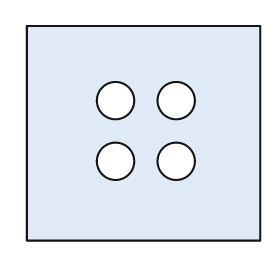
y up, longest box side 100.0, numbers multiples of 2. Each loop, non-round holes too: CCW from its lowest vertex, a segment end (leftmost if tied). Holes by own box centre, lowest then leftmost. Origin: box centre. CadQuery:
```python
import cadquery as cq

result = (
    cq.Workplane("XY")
    .moveTo(-50.0, -46.0)
    .lineTo(50.0, -46.0)
    .lineTo(50.0, 46.0)
    .lineTo(-50.0, 46.0)
    .close()
    .moveTo(-12.0, -12.0)
    .circle(8.0)
    .moveTo(14.0, -12.0)
    .circle(8.0)
    .moveTo(-12.0, 14.0)
    .circle(8.0)
    .moveTo(14.0, 14.0)
    .circle(8.0)
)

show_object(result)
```